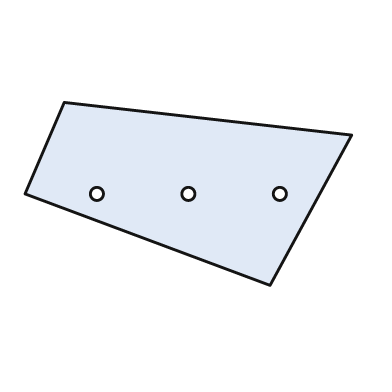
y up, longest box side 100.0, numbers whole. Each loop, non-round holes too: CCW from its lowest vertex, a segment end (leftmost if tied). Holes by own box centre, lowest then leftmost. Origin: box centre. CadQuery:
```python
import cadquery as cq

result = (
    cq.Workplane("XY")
    .moveTo(25.0, -28.0)
    .lineTo(50.0, 18.0)
    .lineTo(-38.0, 28.0)
    .lineTo(-50.0, 0.0)
    .close()
    .moveTo(-28.0, 0.0)
    .circle(2.0)
    .moveTo(0.0, 0.0)
    .circle(2.0)
    .moveTo(28.0, 0.0)
    .circle(2.0)
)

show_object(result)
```